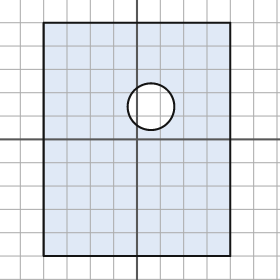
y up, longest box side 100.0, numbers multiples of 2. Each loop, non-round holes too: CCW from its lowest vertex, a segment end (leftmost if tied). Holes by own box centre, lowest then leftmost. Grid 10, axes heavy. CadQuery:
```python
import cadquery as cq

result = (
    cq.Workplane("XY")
    .moveTo(-40.0, -50.0)
    .lineTo(40.0, -50.0)
    .lineTo(40.0, 50.0)
    .lineTo(-40.0, 50.0)
    .close()
    .moveTo(6.0, 14.0)
    .circle(10.0)
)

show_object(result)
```